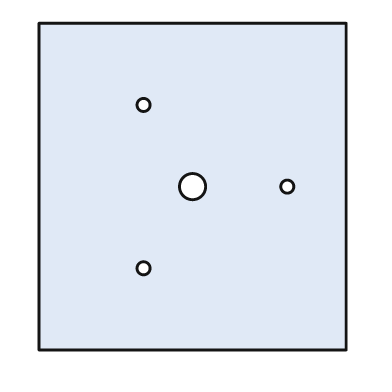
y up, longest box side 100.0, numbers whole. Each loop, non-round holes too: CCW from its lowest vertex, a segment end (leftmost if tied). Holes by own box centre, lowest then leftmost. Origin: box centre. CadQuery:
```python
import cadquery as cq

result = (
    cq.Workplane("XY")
    .moveTo(-47.0, -50.0)
    .lineTo(47.0, -50.0)
    .lineTo(47.0, 50.0)
    .lineTo(-47.0, 50.0)
    .close()
    .moveTo(-15.0, -25.0)
    .circle(2.0)
    .moveTo(0.0, 0.0)
    .circle(4.0)
    .moveTo(29.0, 0.0)
    .circle(2.0)
    .moveTo(-15.0, 25.0)
    .circle(2.0)
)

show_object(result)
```